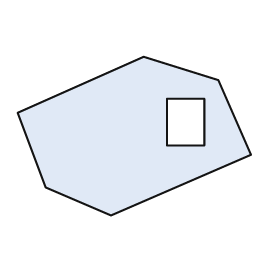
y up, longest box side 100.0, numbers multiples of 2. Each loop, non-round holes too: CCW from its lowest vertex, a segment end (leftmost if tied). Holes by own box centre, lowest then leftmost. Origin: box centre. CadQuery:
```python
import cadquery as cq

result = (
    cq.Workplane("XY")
    .moveTo(-10.0, -34.0)
    .lineTo(50.0, -8.0)
    .lineTo(36.0, 24.0)
    .lineTo(4.0, 34.0)
    .lineTo(-50.0, 10.0)
    .lineTo(-38.0, -22.0)
    .close()
    .moveTo(14.0, -4.0)
    .lineTo(30.0, -4.0)
    .lineTo(30.0, 16.0)
    .lineTo(14.0, 16.0)
    .close()
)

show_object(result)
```